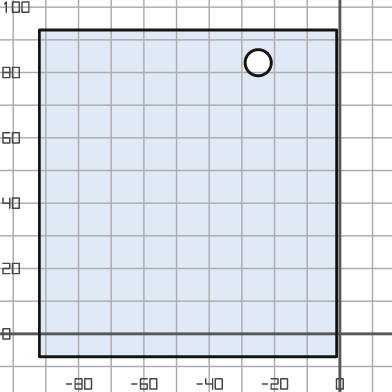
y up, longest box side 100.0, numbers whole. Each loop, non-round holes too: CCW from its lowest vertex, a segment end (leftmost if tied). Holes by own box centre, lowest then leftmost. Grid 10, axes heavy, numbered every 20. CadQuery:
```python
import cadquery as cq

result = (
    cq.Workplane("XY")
    .moveTo(-92.0, -7.0)
    .lineTo(-1.0, -7.0)
    .lineTo(-1.0, 93.0)
    .lineTo(-92.0, 93.0)
    .close()
    .moveTo(-25.0, 83.0)
    .circle(4.0)
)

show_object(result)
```